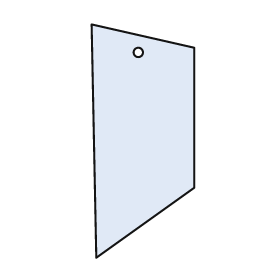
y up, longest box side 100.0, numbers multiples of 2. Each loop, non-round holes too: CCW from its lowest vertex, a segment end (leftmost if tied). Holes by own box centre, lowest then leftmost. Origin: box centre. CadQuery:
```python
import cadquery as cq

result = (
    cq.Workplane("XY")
    .moveTo(-20.0, -50.0)
    .lineTo(22.0, -20.0)
    .lineTo(22.0, 40.0)
    .lineTo(-22.0, 50.0)
    .close()
    .moveTo(-2.0, 38.0)
    .circle(2.0)
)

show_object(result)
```